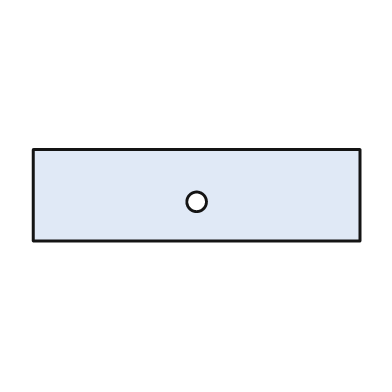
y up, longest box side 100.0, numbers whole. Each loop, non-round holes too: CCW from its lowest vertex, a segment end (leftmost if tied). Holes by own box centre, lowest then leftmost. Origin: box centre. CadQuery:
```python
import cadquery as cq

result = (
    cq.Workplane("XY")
    .moveTo(-50.0, -14.0)
    .lineTo(50.0, -14.0)
    .lineTo(50.0, 14.0)
    .lineTo(-50.0, 14.0)
    .close()
    .moveTo(0.0, -2.0)
    .circle(3.0)
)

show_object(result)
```